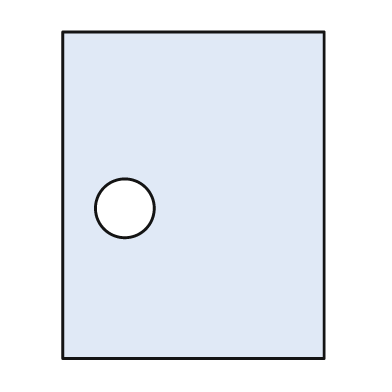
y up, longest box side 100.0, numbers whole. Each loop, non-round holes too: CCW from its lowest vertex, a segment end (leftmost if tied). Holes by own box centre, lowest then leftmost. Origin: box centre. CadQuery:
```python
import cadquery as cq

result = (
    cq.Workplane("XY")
    .moveTo(-40.0, -50.0)
    .lineTo(40.0, -50.0)
    .lineTo(40.0, 50.0)
    .lineTo(-40.0, 50.0)
    .close()
    .moveTo(-21.0, -4.0)
    .circle(9.0)
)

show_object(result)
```